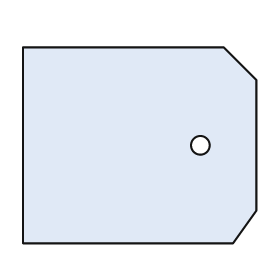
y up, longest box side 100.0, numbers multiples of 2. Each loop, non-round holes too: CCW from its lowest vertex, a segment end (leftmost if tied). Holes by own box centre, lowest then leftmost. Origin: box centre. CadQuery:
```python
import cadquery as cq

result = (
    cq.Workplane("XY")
    .moveTo(-50.0, -42.0)
    .lineTo(40.0, -42.0)
    .lineTo(50.0, -28.0)
    .lineTo(50.0, 28.0)
    .lineTo(36.0, 42.0)
    .lineTo(-50.0, 42.0)
    .close()
    .moveTo(26.0, 0.0)
    .circle(4.0)
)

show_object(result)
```